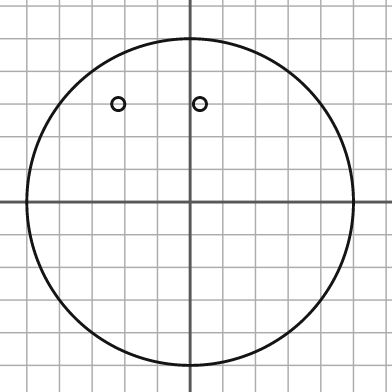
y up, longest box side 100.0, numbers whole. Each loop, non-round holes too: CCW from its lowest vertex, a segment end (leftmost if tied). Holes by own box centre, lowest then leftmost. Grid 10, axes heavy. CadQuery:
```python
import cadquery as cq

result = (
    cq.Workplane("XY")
    .moveTo(0.0, 0.0)
    .circle(50.0)
    .moveTo(-22.0, 30.0)
    .circle(2.0)
    .moveTo(3.0, 30.0)
    .circle(2.0)
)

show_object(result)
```